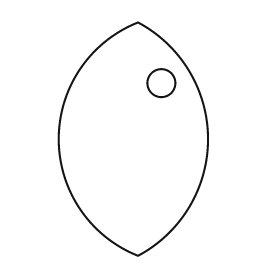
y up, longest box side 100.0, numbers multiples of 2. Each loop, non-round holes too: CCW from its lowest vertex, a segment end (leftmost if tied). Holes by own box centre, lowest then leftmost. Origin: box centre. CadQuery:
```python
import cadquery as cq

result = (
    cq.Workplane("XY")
    .moveTo(2.0, -50.0)
    .threePointArc((32.0, 0.0), (2.0, 50.0))
    .threePointArc((-32.0, 0.0), (2.0, -50.0))
    .close()
    .moveTo(12.0, 24.0)
    .circle(6.0)
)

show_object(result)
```